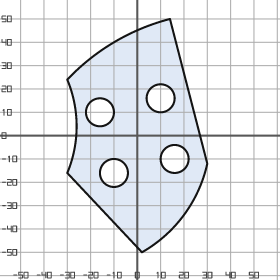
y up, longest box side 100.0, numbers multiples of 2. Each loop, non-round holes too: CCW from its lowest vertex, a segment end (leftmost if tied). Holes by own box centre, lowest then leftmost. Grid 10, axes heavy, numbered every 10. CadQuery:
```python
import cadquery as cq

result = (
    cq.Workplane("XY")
    .moveTo(2.0, -50.0)
    .threePointArc((20.0, -34.0), (30.0, -12.0))
    .lineTo(14.0, 50.0)
    .threePointArc((-10.0, 40.0), (-30.0, 24.0))
    .threePointArc((-26.0, 4.0), (-30.0, -16.0))
    .close()
    .moveTo(-10.0, -16.0)
    .circle(6.0)
    .moveTo(16.0, -10.0)
    .circle(6.0)
    .moveTo(-16.0, 10.0)
    .circle(6.0)
    .moveTo(10.0, 16.0)
    .circle(6.0)
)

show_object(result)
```